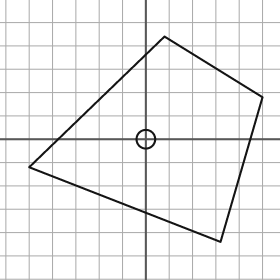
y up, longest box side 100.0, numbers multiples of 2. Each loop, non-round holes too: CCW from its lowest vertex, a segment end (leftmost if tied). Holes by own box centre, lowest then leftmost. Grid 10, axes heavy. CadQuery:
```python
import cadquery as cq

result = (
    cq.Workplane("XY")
    .moveTo(32.0, -44.0)
    .lineTo(50.0, 18.0)
    .lineTo(8.0, 44.0)
    .lineTo(-50.0, -12.0)
    .close()
    .moveTo(0.0, 0.0)
    .circle(4.0)
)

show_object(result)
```